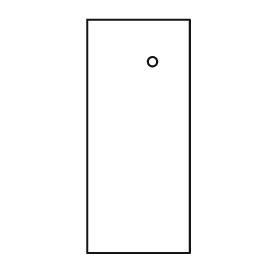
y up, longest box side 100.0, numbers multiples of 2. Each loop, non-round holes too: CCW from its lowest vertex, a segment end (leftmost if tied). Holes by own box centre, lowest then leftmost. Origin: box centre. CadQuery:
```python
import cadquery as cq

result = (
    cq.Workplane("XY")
    .moveTo(-22.0, -50.0)
    .lineTo(22.0, -50.0)
    .lineTo(22.0, 50.0)
    .lineTo(-22.0, 50.0)
    .close()
    .moveTo(6.0, 32.0)
    .circle(2.0)
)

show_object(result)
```